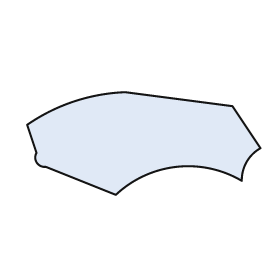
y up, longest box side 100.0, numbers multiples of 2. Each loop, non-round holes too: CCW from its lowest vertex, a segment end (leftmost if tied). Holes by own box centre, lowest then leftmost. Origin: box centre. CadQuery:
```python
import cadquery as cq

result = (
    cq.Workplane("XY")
    .moveTo(-12.0, -22.0)
    .threePointArc((14.0, -10.0), (42.0, -16.0))
    .threePointArc((44.0, -8.0), (50.0, -2.0))
    .lineTo(38.0, 16.0)
    .lineTo(-8.0, 22.0)
    .threePointArc((-30.0, 18.0), (-50.0, 8.0))
    .lineTo(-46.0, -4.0)
    .threePointArc((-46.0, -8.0), (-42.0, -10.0))
    .close()
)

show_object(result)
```